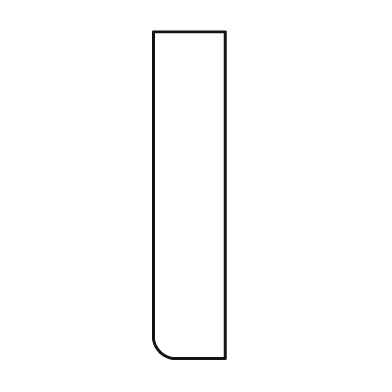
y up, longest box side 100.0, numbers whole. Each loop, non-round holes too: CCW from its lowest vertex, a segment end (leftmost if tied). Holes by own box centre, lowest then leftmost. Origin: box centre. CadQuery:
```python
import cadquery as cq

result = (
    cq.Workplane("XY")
    .moveTo(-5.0, -50.0)
    .lineTo(11.0, -50.0)
    .lineTo(11.0, 50.0)
    .lineTo(-11.0, 50.0)
    .lineTo(-11.0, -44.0)
    .threePointArc((-9.0, -48.0), (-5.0, -50.0))
    .close()
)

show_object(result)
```